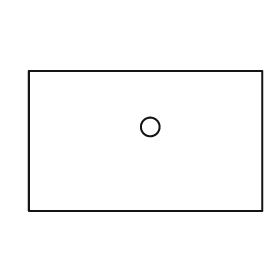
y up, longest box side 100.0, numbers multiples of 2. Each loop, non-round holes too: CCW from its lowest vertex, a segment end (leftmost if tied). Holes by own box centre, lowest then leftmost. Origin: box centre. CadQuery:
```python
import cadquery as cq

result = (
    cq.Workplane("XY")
    .moveTo(-50.0, -30.0)
    .lineTo(50.0, -30.0)
    .lineTo(50.0, 30.0)
    .lineTo(-50.0, 30.0)
    .close()
    .moveTo(2.0, 6.0)
    .circle(4.0)
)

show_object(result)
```